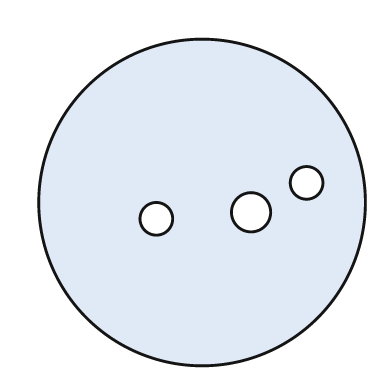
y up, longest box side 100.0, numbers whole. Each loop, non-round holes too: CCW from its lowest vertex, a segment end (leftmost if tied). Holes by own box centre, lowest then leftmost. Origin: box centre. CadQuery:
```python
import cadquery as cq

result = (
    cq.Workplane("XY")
    .moveTo(0.0, 0.0)
    .circle(50.0)
    .moveTo(-14.0, -5.0)
    .circle(5.0)
    .moveTo(15.0, -3.0)
    .circle(6.0)
    .moveTo(32.0, 6.0)
    .circle(5.0)
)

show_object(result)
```